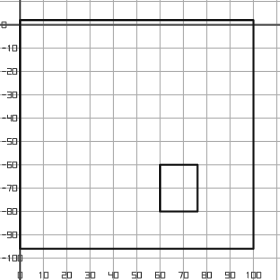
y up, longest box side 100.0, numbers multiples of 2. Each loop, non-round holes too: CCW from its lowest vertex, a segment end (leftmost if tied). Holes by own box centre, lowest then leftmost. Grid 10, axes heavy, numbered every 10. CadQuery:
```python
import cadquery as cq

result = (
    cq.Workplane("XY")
    .moveTo(0.0, -96.0)
    .lineTo(100.0, -96.0)
    .lineTo(100.0, 2.0)
    .lineTo(0.0, 2.0)
    .close()
    .moveTo(60.0, -80.0)
    .lineTo(76.0, -80.0)
    .lineTo(76.0, -60.0)
    .lineTo(60.0, -60.0)
    .close()
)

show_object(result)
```